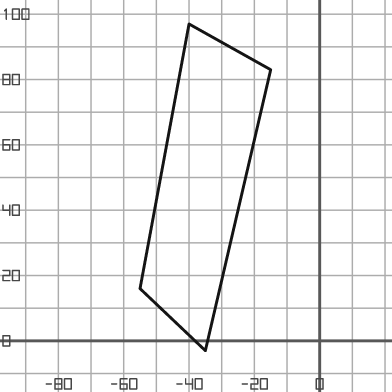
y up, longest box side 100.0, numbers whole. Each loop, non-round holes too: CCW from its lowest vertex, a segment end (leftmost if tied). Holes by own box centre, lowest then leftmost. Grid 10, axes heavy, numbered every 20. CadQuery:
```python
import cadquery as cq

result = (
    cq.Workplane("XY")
    .moveTo(-35.0, -3.0)
    .lineTo(-15.0, 83.0)
    .lineTo(-40.0, 97.0)
    .lineTo(-55.0, 16.0)
    .close()
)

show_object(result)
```